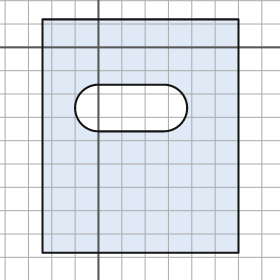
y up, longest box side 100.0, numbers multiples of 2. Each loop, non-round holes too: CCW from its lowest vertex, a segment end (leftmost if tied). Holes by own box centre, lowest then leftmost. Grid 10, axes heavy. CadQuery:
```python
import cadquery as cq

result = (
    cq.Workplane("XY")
    .moveTo(-24.0, -88.0)
    .lineTo(60.0, -88.0)
    .lineTo(60.0, 12.0)
    .lineTo(-24.0, 12.0)
    .close()
    .moveTo(0.0, -36.0)
    .lineTo(28.0, -36.0)
    .threePointArc((38.0, -26.0), (28.0, -16.0))
    .lineTo(0.0, -16.0)
    .threePointArc((-10.0, -26.0), (0.0, -36.0))
    .close()
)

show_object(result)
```